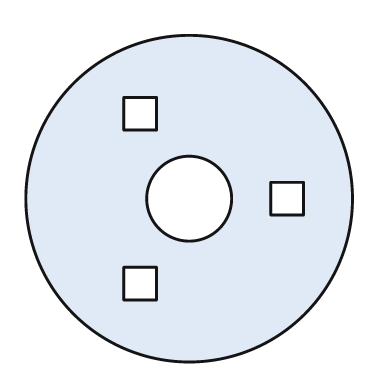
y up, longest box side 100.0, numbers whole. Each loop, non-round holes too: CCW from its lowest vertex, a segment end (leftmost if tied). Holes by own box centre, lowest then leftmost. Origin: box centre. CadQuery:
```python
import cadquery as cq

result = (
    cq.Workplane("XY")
    .moveTo(0.0, 0.0)
    .circle(50.0)
    .moveTo(-20.0, -31.0)
    .lineTo(-10.0, -31.0)
    .lineTo(-10.0, -21.0)
    .lineTo(-20.0, -21.0)
    .close()
    .moveTo(0.0, 0.0)
    .circle(13.0)
    .moveTo(25.0, -5.0)
    .lineTo(35.0, -5.0)
    .lineTo(35.0, 5.0)
    .lineTo(25.0, 5.0)
    .close()
    .moveTo(-20.0, 21.0)
    .lineTo(-10.0, 21.0)
    .lineTo(-10.0, 31.0)
    .lineTo(-20.0, 31.0)
    .close()
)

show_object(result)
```